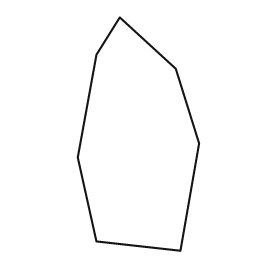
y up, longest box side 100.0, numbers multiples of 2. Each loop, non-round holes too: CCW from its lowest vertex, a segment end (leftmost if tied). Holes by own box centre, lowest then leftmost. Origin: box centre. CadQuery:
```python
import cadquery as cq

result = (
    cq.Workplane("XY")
    .moveTo(18.0, -50.0)
    .lineTo(26.0, -4.0)
    .lineTo(16.0, 28.0)
    .lineTo(-8.0, 50.0)
    .lineTo(-18.0, 34.0)
    .lineTo(-26.0, -10.0)
    .lineTo(-18.0, -46.0)
    .close()
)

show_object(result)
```